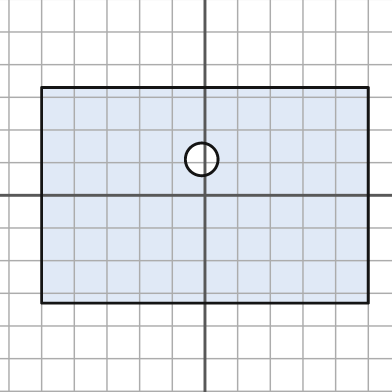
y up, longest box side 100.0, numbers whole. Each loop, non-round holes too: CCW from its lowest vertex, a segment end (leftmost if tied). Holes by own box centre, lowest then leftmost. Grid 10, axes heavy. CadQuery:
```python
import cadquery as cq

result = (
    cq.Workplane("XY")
    .moveTo(-50.0, -33.0)
    .lineTo(50.0, -33.0)
    .lineTo(50.0, 33.0)
    .lineTo(-50.0, 33.0)
    .close()
    .moveTo(-1.0, 11.0)
    .circle(5.0)
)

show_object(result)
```